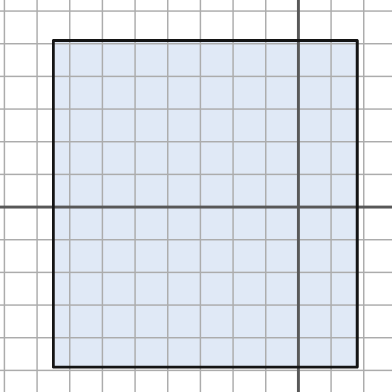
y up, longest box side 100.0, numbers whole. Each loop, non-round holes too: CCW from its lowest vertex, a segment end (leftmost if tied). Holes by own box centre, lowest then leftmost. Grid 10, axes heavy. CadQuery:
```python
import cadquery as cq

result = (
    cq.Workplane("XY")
    .moveTo(-75.0, -49.0)
    .lineTo(18.0, -49.0)
    .lineTo(18.0, 51.0)
    .lineTo(-75.0, 51.0)
    .close()
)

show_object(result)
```